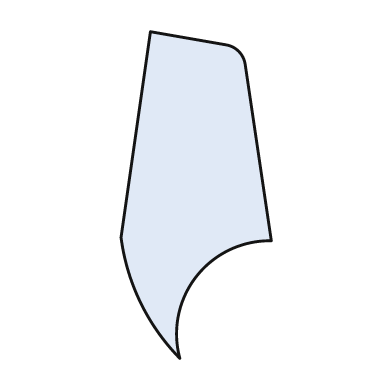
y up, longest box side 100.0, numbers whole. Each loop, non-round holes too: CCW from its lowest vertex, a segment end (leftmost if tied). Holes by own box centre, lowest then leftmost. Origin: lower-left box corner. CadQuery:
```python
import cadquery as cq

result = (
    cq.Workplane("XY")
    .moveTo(18.0, 0.0)
    .threePointArc((23.0, 25.0), (46.0, 36.0))
    .lineTo(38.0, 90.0)
    .threePointArc((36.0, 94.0), (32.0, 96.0))
    .lineTo(9.0, 100.0)
    .lineTo(0.0, 37.0)
    .threePointArc((6.0, 17.0), (18.0, 0.0))
    .close()
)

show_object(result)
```